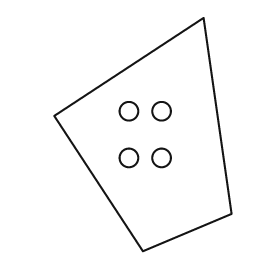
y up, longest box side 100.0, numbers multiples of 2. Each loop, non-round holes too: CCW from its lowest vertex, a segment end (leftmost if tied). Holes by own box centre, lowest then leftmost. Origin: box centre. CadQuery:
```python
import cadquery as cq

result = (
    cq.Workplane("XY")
    .moveTo(0.0, -50.0)
    .lineTo(38.0, -34.0)
    .lineTo(26.0, 50.0)
    .lineTo(-38.0, 8.0)
    .close()
    .moveTo(-6.0, -10.0)
    .circle(4.0)
    .moveTo(8.0, -10.0)
    .circle(4.0)
    .moveTo(-6.0, 10.0)
    .circle(4.0)
    .moveTo(8.0, 10.0)
    .circle(4.0)
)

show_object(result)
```